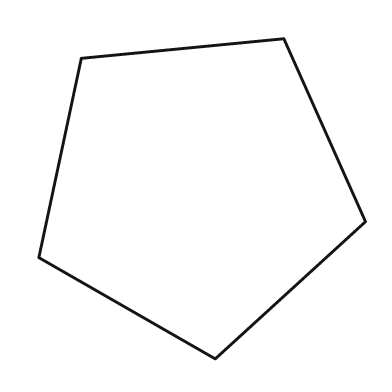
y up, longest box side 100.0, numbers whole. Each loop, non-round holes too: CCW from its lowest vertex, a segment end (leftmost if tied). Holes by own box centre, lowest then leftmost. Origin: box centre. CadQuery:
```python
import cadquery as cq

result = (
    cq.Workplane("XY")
    .moveTo(4.0, -49.0)
    .lineTo(50.0, -7.0)
    .lineTo(25.0, 49.0)
    .lineTo(-37.0, 43.0)
    .lineTo(-50.0, -18.0)
    .close()
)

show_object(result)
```